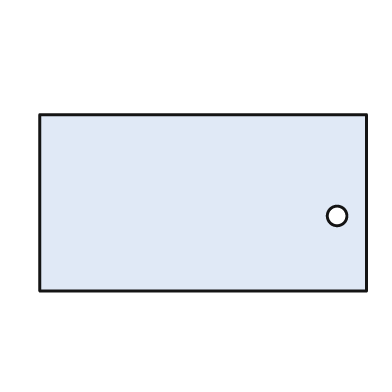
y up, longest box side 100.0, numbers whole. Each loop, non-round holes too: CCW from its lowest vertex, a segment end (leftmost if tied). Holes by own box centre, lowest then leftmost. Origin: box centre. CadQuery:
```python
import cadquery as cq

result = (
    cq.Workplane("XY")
    .moveTo(-50.0, -27.0)
    .lineTo(50.0, -27.0)
    .lineTo(50.0, 27.0)
    .lineTo(-50.0, 27.0)
    .close()
    .moveTo(41.0, -4.0)
    .circle(3.0)
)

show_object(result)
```